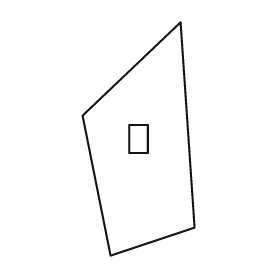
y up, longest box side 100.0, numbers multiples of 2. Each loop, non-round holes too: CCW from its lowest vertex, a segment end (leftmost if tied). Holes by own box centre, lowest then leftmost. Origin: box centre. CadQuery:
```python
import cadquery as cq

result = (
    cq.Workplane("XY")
    .moveTo(-12.0, -50.0)
    .lineTo(24.0, -38.0)
    .lineTo(18.0, 50.0)
    .lineTo(-24.0, 10.0)
    .close()
    .moveTo(-4.0, -6.0)
    .lineTo(4.0, -6.0)
    .lineTo(4.0, 6.0)
    .lineTo(-4.0, 6.0)
    .close()
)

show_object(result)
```